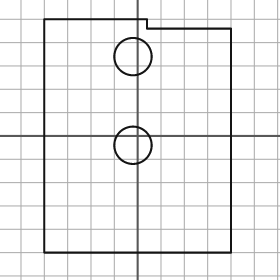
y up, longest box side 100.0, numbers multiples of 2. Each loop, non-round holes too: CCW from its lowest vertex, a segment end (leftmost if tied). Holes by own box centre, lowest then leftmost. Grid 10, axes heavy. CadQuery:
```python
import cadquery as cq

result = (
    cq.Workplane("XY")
    .moveTo(-40.0, -50.0)
    .lineTo(40.0, -50.0)
    .lineTo(40.0, 46.0)
    .lineTo(4.0, 46.0)
    .lineTo(4.0, 50.0)
    .lineTo(-40.0, 50.0)
    .close()
    .moveTo(-2.0, -4.0)
    .circle(8.0)
    .moveTo(-2.0, 34.0)
    .circle(8.0)
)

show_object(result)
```